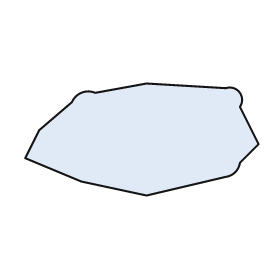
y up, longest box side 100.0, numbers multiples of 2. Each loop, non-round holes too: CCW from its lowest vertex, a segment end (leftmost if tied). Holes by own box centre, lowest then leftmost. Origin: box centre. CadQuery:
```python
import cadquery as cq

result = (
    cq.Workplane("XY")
    .moveTo(2.0, -24.0)
    .lineTo(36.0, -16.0)
    .threePointArc((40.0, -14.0), (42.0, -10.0))
    .lineTo(50.0, -2.0)
    .lineTo(42.0, 14.0)
    .threePointArc((42.0, 20.0), (36.0, 22.0))
    .lineTo(2.0, 24.0)
    .lineTo(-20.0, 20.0)
    .threePointArc((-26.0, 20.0), (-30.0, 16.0))
    .lineTo(-44.0, 4.0)
    .lineTo(-50.0, -8.0)
    .lineTo(-26.0, -18.0)
    .close()
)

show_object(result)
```